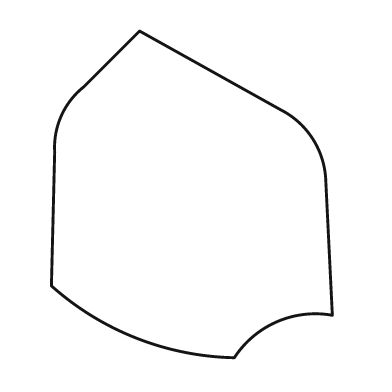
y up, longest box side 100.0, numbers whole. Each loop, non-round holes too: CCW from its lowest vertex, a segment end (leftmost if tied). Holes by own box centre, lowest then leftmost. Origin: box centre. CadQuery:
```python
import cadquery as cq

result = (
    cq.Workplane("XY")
    .moveTo(13.0, -50.0)
    .threePointArc((26.0, -39.0), (43.0, -37.0))
    .lineTo(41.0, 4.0)
    .threePointArc((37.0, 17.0), (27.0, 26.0))
    .lineTo(-16.0, 50.0)
    .lineTo(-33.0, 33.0)
    .threePointArc((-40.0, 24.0), (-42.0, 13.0))
    .lineTo(-43.0, -28.0)
    .threePointArc((-17.0, -44.0), (13.0, -50.0))
    .close()
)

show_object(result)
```